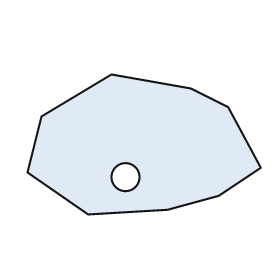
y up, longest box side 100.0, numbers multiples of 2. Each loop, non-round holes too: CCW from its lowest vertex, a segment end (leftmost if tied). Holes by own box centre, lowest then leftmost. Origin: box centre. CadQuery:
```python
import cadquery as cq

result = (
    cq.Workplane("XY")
    .moveTo(-24.0, -30.0)
    .lineTo(10.0, -28.0)
    .lineTo(32.0, -22.0)
    .lineTo(50.0, -10.0)
    .lineTo(36.0, 16.0)
    .lineTo(20.0, 24.0)
    .lineTo(-14.0, 30.0)
    .lineTo(-44.0, 12.0)
    .lineTo(-50.0, -12.0)
    .close()
    .moveTo(-8.0, -14.0)
    .circle(6.0)
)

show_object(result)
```